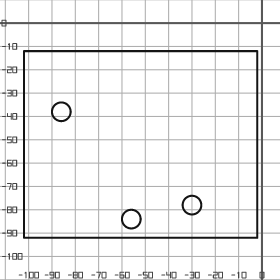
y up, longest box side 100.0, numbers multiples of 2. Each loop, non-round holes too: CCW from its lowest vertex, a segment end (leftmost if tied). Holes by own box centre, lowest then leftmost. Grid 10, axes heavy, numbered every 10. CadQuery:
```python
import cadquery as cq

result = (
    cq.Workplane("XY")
    .moveTo(-102.0, -92.0)
    .lineTo(-2.0, -92.0)
    .lineTo(-2.0, -12.0)
    .lineTo(-102.0, -12.0)
    .close()
    .moveTo(-56.0, -84.0)
    .circle(4.0)
    .moveTo(-30.0, -78.0)
    .circle(4.0)
    .moveTo(-86.0, -38.0)
    .circle(4.0)
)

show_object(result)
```